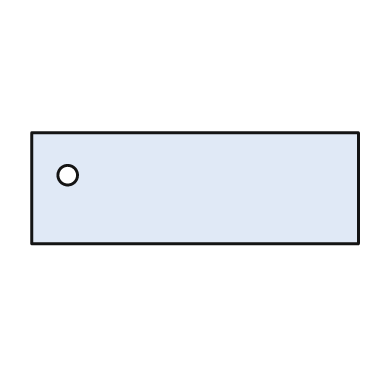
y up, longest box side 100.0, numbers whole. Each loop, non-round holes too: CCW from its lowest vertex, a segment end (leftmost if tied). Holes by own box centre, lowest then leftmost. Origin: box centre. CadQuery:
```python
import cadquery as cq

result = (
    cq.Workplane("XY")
    .moveTo(-50.0, -17.0)
    .lineTo(50.0, -17.0)
    .lineTo(50.0, 17.0)
    .lineTo(-50.0, 17.0)
    .close()
    .moveTo(-39.0, 4.0)
    .circle(3.0)
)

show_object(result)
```